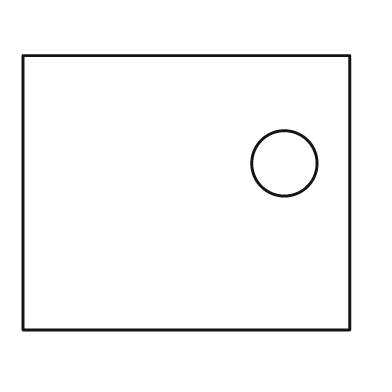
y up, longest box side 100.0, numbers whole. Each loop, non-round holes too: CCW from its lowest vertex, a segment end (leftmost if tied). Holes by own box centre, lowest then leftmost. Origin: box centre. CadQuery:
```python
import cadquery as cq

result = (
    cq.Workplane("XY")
    .moveTo(-50.0, -42.0)
    .lineTo(50.0, -42.0)
    .lineTo(50.0, 42.0)
    .lineTo(-50.0, 42.0)
    .close()
    .moveTo(30.0, 9.0)
    .circle(10.0)
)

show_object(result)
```